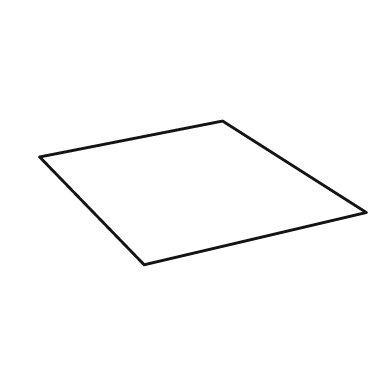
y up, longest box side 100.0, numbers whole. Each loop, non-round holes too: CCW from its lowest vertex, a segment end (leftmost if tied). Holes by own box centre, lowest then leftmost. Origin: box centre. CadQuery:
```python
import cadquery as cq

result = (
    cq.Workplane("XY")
    .moveTo(-18.0, -22.0)
    .lineTo(50.0, -6.0)
    .lineTo(6.0, 22.0)
    .lineTo(-50.0, 11.0)
    .close()
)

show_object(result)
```